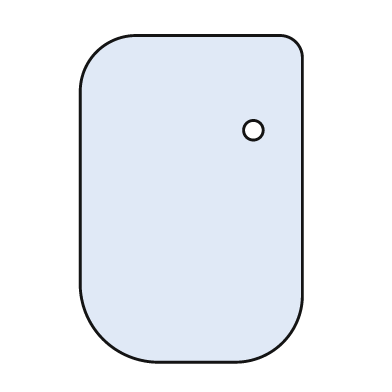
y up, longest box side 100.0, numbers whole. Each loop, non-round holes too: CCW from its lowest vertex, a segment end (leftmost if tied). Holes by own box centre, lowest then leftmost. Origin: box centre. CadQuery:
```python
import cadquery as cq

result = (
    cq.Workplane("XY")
    .moveTo(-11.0, -50.0)
    .lineTo(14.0, -50.0)
    .threePointArc((28.0, -44.0), (34.0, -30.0))
    .lineTo(34.0, 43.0)
    .threePointArc((32.0, 48.0), (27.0, 50.0))
    .lineTo(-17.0, 50.0)
    .threePointArc((-29.0, 45.0), (-34.0, 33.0))
    .lineTo(-34.0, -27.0)
    .threePointArc((-27.0, -43.0), (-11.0, -50.0))
    .close()
    .moveTo(19.0, 21.0)
    .circle(3.0)
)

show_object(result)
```